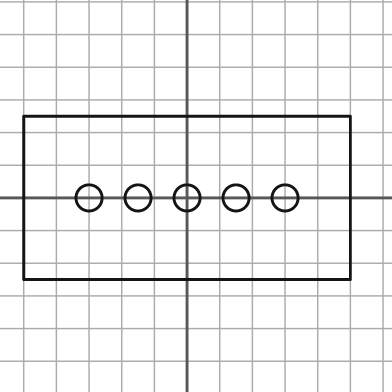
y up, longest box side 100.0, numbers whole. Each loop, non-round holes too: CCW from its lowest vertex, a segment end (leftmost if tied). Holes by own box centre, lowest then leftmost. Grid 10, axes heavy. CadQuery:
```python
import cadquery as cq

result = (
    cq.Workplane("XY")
    .moveTo(-50.0, -25.0)
    .lineTo(50.0, -25.0)
    .lineTo(50.0, 25.0)
    .lineTo(-50.0, 25.0)
    .close()
    .moveTo(-30.0, 0.0)
    .circle(4.0)
    .moveTo(-15.0, 0.0)
    .circle(4.0)
    .moveTo(0.0, 0.0)
    .circle(4.0)
    .moveTo(15.0, 0.0)
    .circle(4.0)
    .moveTo(30.0, 0.0)
    .circle(4.0)
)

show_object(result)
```